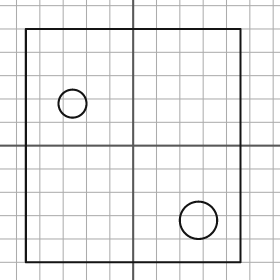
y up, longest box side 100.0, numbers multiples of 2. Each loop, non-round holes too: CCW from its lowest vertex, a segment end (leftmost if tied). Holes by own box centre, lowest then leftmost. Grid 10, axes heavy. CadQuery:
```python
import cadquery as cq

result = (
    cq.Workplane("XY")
    .moveTo(-46.0, -50.0)
    .lineTo(46.0, -50.0)
    .lineTo(46.0, 50.0)
    .lineTo(-46.0, 50.0)
    .close()
    .moveTo(28.0, -32.0)
    .circle(8.0)
    .moveTo(-26.0, 18.0)
    .circle(6.0)
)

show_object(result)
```